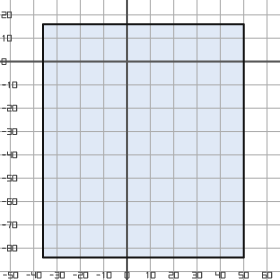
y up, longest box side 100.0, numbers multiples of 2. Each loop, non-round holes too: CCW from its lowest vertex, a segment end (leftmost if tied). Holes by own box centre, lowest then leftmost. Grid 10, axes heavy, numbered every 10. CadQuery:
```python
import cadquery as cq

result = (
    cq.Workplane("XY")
    .moveTo(-36.0, -84.0)
    .lineTo(50.0, -84.0)
    .lineTo(50.0, 16.0)
    .lineTo(-36.0, 16.0)
    .close()
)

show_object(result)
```